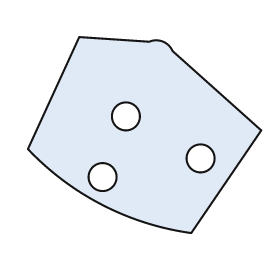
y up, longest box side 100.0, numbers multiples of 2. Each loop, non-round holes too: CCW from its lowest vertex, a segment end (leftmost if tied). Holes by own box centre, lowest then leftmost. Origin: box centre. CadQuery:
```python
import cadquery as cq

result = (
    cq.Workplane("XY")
    .moveTo(20.0, -42.0)
    .lineTo(50.0, 2.0)
    .lineTo(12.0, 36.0)
    .threePointArc((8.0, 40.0), (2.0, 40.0))
    .lineTo(-28.0, 42.0)
    .lineTo(-50.0, -6.0)
    .threePointArc((-18.0, -30.0), (20.0, -42.0))
    .close()
    .moveTo(-18.0, -18.0)
    .circle(6.0)
    .moveTo(24.0, -10.0)
    .circle(6.0)
    .moveTo(-8.0, 8.0)
    .circle(6.0)
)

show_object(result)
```